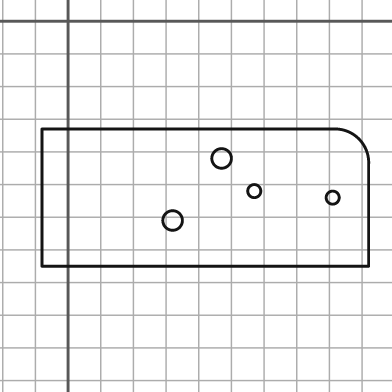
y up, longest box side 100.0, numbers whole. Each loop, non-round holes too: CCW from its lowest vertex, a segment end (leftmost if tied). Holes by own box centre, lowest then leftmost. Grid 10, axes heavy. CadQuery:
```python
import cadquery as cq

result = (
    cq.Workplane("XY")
    .moveTo(-8.0, -75.0)
    .lineTo(92.0, -75.0)
    .lineTo(92.0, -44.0)
    .threePointArc((89.0, -36.0), (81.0, -33.0))
    .lineTo(-8.0, -33.0)
    .close()
    .moveTo(32.0, -61.0)
    .circle(3.0)
    .moveTo(81.0, -54.0)
    .circle(2.0)
    .moveTo(57.0, -52.0)
    .circle(2.0)
    .moveTo(47.0, -42.0)
    .circle(3.0)
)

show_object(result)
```